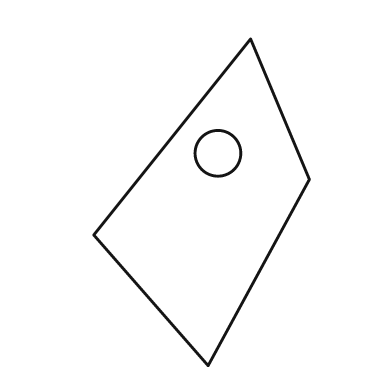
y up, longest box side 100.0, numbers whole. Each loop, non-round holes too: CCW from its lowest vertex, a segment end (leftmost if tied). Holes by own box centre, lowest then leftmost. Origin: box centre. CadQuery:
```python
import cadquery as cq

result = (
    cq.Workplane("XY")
    .moveTo(2.0, -50.0)
    .lineTo(33.0, 7.0)
    .lineTo(15.0, 50.0)
    .lineTo(-33.0, -10.0)
    .close()
    .moveTo(5.0, 15.0)
    .circle(7.0)
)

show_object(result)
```